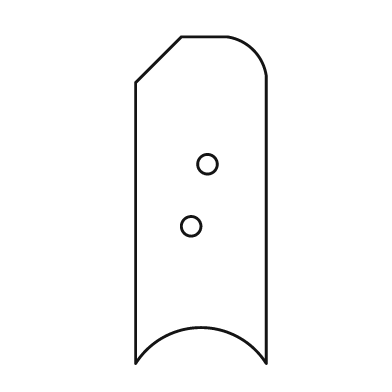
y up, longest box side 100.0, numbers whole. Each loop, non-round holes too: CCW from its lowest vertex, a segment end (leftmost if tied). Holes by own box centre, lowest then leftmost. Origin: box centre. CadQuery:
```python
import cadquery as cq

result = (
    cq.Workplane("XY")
    .moveTo(-20.0, -50.0)
    .threePointArc((0.0, -39.0), (20.0, -50.0))
    .lineTo(20.0, 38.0)
    .threePointArc((16.0, 46.0), (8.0, 50.0))
    .lineTo(-6.0, 50.0)
    .lineTo(-20.0, 36.0)
    .close()
    .moveTo(-3.0, -8.0)
    .circle(3.0)
    .moveTo(2.0, 11.0)
    .circle(3.0)
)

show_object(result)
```